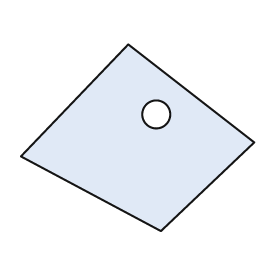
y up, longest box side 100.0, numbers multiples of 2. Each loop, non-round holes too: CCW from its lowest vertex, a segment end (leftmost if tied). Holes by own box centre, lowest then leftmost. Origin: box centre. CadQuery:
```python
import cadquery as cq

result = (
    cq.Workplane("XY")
    .moveTo(10.0, -40.0)
    .lineTo(50.0, -2.0)
    .lineTo(-4.0, 40.0)
    .lineTo(-50.0, -8.0)
    .close()
    .moveTo(8.0, 10.0)
    .circle(6.0)
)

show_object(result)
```